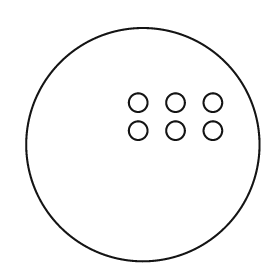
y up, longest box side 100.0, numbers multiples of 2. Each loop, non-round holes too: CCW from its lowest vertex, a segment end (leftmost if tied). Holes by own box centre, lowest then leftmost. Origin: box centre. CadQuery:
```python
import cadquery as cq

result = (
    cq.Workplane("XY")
    .moveTo(0.0, 0.0)
    .circle(50.0)
    .moveTo(-2.0, 6.0)
    .circle(4.0)
    .moveTo(14.0, 6.0)
    .circle(4.0)
    .moveTo(30.0, 6.0)
    .circle(4.0)
    .moveTo(-2.0, 18.0)
    .circle(4.0)
    .moveTo(14.0, 18.0)
    .circle(4.0)
    .moveTo(30.0, 18.0)
    .circle(4.0)
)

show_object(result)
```